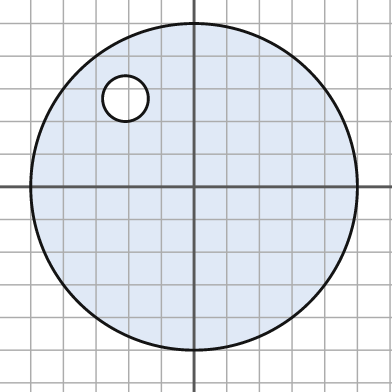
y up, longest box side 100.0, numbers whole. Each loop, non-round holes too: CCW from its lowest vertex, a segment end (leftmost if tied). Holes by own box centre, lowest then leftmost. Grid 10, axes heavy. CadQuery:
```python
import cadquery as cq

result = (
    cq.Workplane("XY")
    .moveTo(0.0, 0.0)
    .circle(50.0)
    .moveTo(-21.0, 27.0)
    .circle(7.0)
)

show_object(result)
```